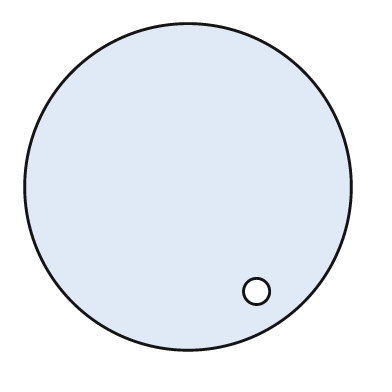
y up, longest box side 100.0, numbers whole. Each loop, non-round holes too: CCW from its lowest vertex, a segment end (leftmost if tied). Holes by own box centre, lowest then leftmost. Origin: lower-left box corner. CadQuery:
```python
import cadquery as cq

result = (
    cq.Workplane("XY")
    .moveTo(50.0, 50.0)
    .circle(50.0)
    .moveTo(71.0, 18.0)
    .circle(4.0)
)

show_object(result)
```